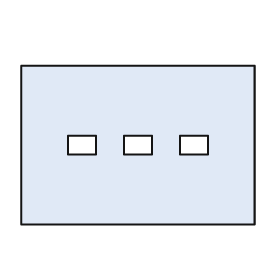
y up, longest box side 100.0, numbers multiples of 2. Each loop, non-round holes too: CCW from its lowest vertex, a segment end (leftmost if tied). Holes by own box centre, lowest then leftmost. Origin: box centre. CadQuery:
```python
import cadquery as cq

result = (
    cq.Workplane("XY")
    .moveTo(-50.0, -34.0)
    .lineTo(50.0, -34.0)
    .lineTo(50.0, 34.0)
    .lineTo(-50.0, 34.0)
    .close()
    .moveTo(-30.0, -4.0)
    .lineTo(-18.0, -4.0)
    .lineTo(-18.0, 4.0)
    .lineTo(-30.0, 4.0)
    .close()
    .moveTo(-6.0, -4.0)
    .lineTo(6.0, -4.0)
    .lineTo(6.0, 4.0)
    .lineTo(-6.0, 4.0)
    .close()
    .moveTo(18.0, -4.0)
    .lineTo(30.0, -4.0)
    .lineTo(30.0, 4.0)
    .lineTo(18.0, 4.0)
    .close()
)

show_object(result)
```